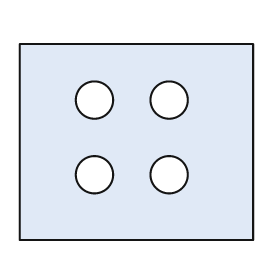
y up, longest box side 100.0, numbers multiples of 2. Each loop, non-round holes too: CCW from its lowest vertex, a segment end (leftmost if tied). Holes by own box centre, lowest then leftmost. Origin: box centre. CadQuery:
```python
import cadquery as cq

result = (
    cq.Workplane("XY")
    .moveTo(-50.0, -42.0)
    .lineTo(50.0, -42.0)
    .lineTo(50.0, 42.0)
    .lineTo(-50.0, 42.0)
    .close()
    .moveTo(-18.0, -14.0)
    .circle(8.0)
    .moveTo(14.0, -14.0)
    .circle(8.0)
    .moveTo(-18.0, 18.0)
    .circle(8.0)
    .moveTo(14.0, 18.0)
    .circle(8.0)
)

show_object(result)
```